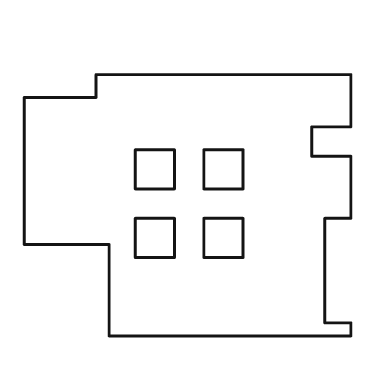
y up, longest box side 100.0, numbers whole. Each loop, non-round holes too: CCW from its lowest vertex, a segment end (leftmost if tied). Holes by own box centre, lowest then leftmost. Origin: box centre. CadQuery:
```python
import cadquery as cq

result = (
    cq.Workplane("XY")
    .moveTo(-24.0, -40.0)
    .lineTo(50.0, -40.0)
    .lineTo(50.0, -36.0)
    .lineTo(42.0, -36.0)
    .lineTo(42.0, -4.0)
    .lineTo(50.0, -4.0)
    .lineTo(50.0, 15.0)
    .lineTo(38.0, 15.0)
    .lineTo(38.0, 24.0)
    .lineTo(50.0, 24.0)
    .lineTo(50.0, 40.0)
    .lineTo(-28.0, 40.0)
    .lineTo(-28.0, 33.0)
    .lineTo(-50.0, 33.0)
    .lineTo(-50.0, -12.0)
    .lineTo(-24.0, -12.0)
    .close()
    .moveTo(-16.0, -16.0)
    .lineTo(-4.0, -16.0)
    .lineTo(-4.0, -4.0)
    .lineTo(-16.0, -4.0)
    .close()
    .moveTo(5.0, -16.0)
    .lineTo(17.0, -16.0)
    .lineTo(17.0, -4.0)
    .lineTo(5.0, -4.0)
    .close()
    .moveTo(-16.0, 5.0)
    .lineTo(-4.0, 5.0)
    .lineTo(-4.0, 17.0)
    .lineTo(-16.0, 17.0)
    .close()
    .moveTo(5.0, 5.0)
    .lineTo(17.0, 5.0)
    .lineTo(17.0, 17.0)
    .lineTo(5.0, 17.0)
    .close()
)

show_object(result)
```